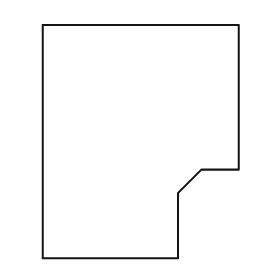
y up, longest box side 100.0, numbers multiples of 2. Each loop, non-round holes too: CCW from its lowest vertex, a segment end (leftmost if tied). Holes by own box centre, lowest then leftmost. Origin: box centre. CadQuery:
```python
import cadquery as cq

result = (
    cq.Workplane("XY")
    .moveTo(-42.0, -50.0)
    .lineTo(16.0, -50.0)
    .lineTo(16.0, -22.0)
    .lineTo(26.0, -12.0)
    .lineTo(42.0, -12.0)
    .lineTo(42.0, 50.0)
    .lineTo(-42.0, 50.0)
    .close()
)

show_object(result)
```